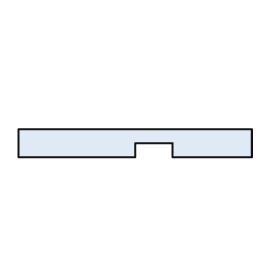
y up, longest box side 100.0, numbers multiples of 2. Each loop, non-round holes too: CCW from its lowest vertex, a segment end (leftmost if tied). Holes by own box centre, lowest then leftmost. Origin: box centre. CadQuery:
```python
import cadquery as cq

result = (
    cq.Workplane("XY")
    .moveTo(-50.0, -6.0)
    .lineTo(0.0, -6.0)
    .lineTo(0.0, 0.0)
    .lineTo(16.0, 0.0)
    .lineTo(16.0, -6.0)
    .lineTo(50.0, -6.0)
    .lineTo(50.0, 6.0)
    .lineTo(-50.0, 6.0)
    .close()
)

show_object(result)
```